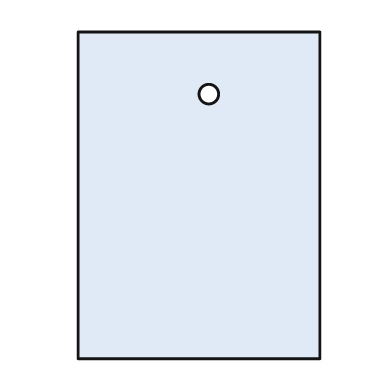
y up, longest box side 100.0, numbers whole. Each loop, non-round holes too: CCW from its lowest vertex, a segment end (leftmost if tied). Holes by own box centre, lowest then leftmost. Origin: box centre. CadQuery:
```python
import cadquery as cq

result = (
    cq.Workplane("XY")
    .moveTo(-37.0, -50.0)
    .lineTo(37.0, -50.0)
    .lineTo(37.0, 50.0)
    .lineTo(-37.0, 50.0)
    .close()
    .moveTo(3.0, 31.0)
    .circle(3.0)
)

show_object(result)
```